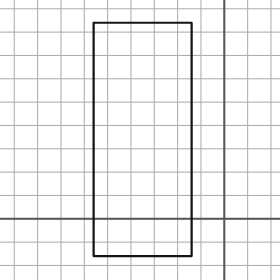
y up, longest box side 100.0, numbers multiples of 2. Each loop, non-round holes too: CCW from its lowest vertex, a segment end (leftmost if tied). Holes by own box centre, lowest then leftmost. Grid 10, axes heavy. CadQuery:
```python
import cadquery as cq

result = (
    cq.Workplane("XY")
    .moveTo(-56.0, -16.0)
    .lineTo(-14.0, -16.0)
    .lineTo(-14.0, 84.0)
    .lineTo(-56.0, 84.0)
    .close()
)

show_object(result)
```